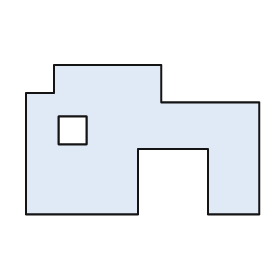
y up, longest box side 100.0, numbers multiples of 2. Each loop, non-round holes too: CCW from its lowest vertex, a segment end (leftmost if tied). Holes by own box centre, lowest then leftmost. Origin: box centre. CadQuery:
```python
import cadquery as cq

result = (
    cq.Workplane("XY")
    .moveTo(-50.0, -32.0)
    .lineTo(-2.0, -32.0)
    .lineTo(-2.0, -4.0)
    .lineTo(28.0, -4.0)
    .lineTo(28.0, -32.0)
    .lineTo(50.0, -32.0)
    .lineTo(50.0, 16.0)
    .lineTo(8.0, 16.0)
    .lineTo(8.0, 32.0)
    .lineTo(-38.0, 32.0)
    .lineTo(-38.0, 20.0)
    .lineTo(-50.0, 20.0)
    .close()
    .moveTo(-36.0, -2.0)
    .lineTo(-24.0, -2.0)
    .lineTo(-24.0, 10.0)
    .lineTo(-36.0, 10.0)
    .close()
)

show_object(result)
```